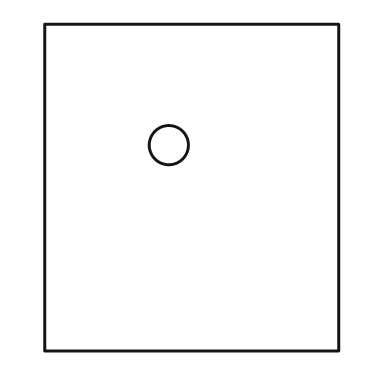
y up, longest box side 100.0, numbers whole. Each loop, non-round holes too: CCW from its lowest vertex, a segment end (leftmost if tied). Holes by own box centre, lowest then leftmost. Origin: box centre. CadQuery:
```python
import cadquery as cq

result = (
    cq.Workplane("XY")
    .moveTo(-45.0, -50.0)
    .lineTo(45.0, -50.0)
    .lineTo(45.0, 50.0)
    .lineTo(-45.0, 50.0)
    .close()
    .moveTo(-7.0, 13.0)
    .circle(6.0)
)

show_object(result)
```